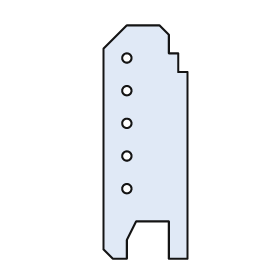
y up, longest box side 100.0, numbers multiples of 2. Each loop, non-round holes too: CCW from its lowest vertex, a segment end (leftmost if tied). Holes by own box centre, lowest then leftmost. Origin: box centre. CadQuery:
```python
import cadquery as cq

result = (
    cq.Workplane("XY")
    .moveTo(-14.0, -50.0)
    .lineTo(-8.0, -50.0)
    .lineTo(-8.0, -42.0)
    .lineTo(-4.0, -34.0)
    .lineTo(10.0, -34.0)
    .lineTo(10.0, -50.0)
    .lineTo(18.0, -50.0)
    .lineTo(18.0, 30.0)
    .lineTo(14.0, 30.0)
    .lineTo(14.0, 38.0)
    .lineTo(10.0, 38.0)
    .lineTo(10.0, 46.0)
    .lineTo(6.0, 50.0)
    .lineTo(-8.0, 50.0)
    .lineTo(-18.0, 40.0)
    .lineTo(-18.0, -46.0)
    .close()
    .moveTo(-8.0, -20.0)
    .circle(2.0)
    .moveTo(-8.0, -6.0)
    .circle(2.0)
    .moveTo(-8.0, 8.0)
    .circle(2.0)
    .moveTo(-8.0, 22.0)
    .circle(2.0)
    .moveTo(-8.0, 36.0)
    .circle(2.0)
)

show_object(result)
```